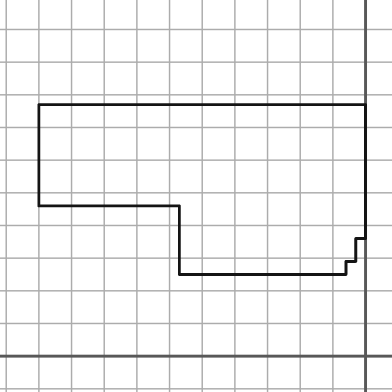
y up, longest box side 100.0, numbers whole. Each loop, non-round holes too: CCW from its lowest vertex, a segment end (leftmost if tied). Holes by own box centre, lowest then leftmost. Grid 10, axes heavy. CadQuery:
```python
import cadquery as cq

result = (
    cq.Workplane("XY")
    .moveTo(-57.0, 25.0)
    .lineTo(-6.0, 25.0)
    .lineTo(-6.0, 29.0)
    .lineTo(-3.0, 29.0)
    .lineTo(-3.0, 36.0)
    .lineTo(0.0, 36.0)
    .lineTo(0.0, 77.0)
    .lineTo(-100.0, 77.0)
    .lineTo(-100.0, 46.0)
    .lineTo(-57.0, 46.0)
    .close()
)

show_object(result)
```